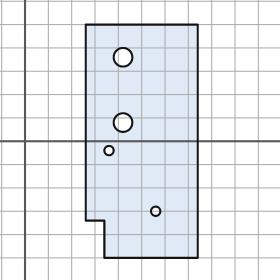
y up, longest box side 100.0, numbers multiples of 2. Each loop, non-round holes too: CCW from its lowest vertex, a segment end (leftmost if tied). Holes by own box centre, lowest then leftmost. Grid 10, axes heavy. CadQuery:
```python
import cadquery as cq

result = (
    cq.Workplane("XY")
    .moveTo(34.0, -50.0)
    .lineTo(74.0, -50.0)
    .lineTo(74.0, 50.0)
    .lineTo(26.0, 50.0)
    .lineTo(26.0, -34.0)
    .lineTo(34.0, -34.0)
    .close()
    .moveTo(56.0, -30.0)
    .circle(2.0)
    .moveTo(36.0, -4.0)
    .circle(2.0)
    .moveTo(42.0, 8.0)
    .circle(4.0)
    .moveTo(42.0, 36.0)
    .circle(4.0)
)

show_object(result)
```